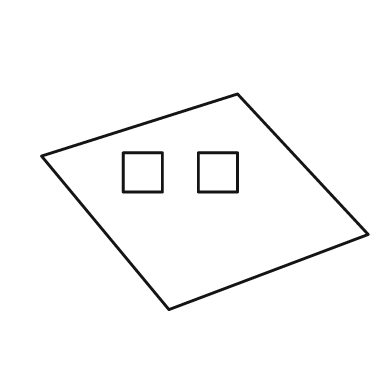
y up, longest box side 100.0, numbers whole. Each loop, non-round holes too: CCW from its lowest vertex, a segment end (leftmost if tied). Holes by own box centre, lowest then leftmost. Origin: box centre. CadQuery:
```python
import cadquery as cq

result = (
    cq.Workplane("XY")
    .moveTo(-11.0, -33.0)
    .lineTo(50.0, -10.0)
    .lineTo(10.0, 33.0)
    .lineTo(-50.0, 14.0)
    .close()
    .moveTo(-25.0, 3.0)
    .lineTo(-13.0, 3.0)
    .lineTo(-13.0, 15.0)
    .lineTo(-25.0, 15.0)
    .close()
    .moveTo(-2.0, 3.0)
    .lineTo(10.0, 3.0)
    .lineTo(10.0, 15.0)
    .lineTo(-2.0, 15.0)
    .close()
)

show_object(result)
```